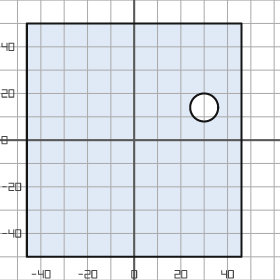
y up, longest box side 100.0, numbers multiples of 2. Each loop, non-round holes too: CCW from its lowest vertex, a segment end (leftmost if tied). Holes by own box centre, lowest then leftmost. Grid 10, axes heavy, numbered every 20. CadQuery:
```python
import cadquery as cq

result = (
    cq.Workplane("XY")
    .moveTo(-46.0, -50.0)
    .lineTo(46.0, -50.0)
    .lineTo(46.0, 50.0)
    .lineTo(-46.0, 50.0)
    .close()
    .moveTo(30.0, 14.0)
    .circle(6.0)
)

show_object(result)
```